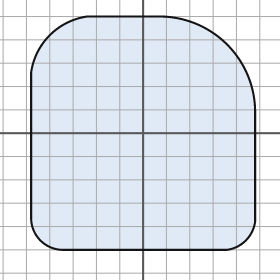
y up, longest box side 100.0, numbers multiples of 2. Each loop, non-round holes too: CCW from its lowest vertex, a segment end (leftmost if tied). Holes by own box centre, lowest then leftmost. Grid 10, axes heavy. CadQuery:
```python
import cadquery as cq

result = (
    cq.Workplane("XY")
    .moveTo(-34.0, -50.0)
    .lineTo(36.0, -50.0)
    .threePointArc((44.0, -46.0), (48.0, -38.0))
    .lineTo(48.0, 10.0)
    .threePointArc((36.0, 38.0), (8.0, 50.0))
    .lineTo(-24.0, 50.0)
    .threePointArc((-40.0, 42.0), (-48.0, 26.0))
    .lineTo(-48.0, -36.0)
    .threePointArc((-44.0, -46.0), (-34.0, -50.0))
    .close()
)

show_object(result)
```